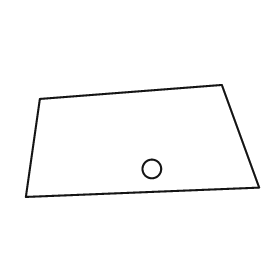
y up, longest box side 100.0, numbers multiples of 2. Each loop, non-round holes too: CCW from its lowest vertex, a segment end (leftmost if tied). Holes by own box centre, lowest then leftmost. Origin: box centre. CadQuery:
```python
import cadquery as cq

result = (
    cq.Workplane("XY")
    .moveTo(-50.0, -24.0)
    .lineTo(50.0, -20.0)
    .lineTo(34.0, 24.0)
    .lineTo(-44.0, 18.0)
    .close()
    .moveTo(4.0, -12.0)
    .circle(4.0)
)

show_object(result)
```